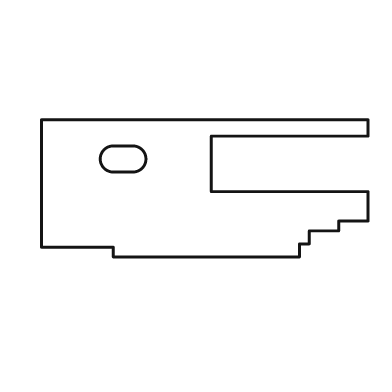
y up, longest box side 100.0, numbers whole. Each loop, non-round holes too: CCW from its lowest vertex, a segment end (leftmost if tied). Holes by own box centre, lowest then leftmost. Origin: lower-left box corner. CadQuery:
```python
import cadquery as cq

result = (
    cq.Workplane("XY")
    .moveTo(22.0, 0.0)
    .lineTo(79.0, 0.0)
    .lineTo(79.0, 4.0)
    .lineTo(82.0, 4.0)
    .lineTo(82.0, 8.0)
    .lineTo(91.0, 8.0)
    .lineTo(91.0, 11.0)
    .lineTo(100.0, 11.0)
    .lineTo(100.0, 20.0)
    .lineTo(52.0, 20.0)
    .lineTo(52.0, 37.0)
    .lineTo(100.0, 37.0)
    .lineTo(100.0, 42.0)
    .lineTo(0.0, 42.0)
    .lineTo(0.0, 3.0)
    .lineTo(22.0, 3.0)
    .close()
    .moveTo(22.0, 26.0)
    .lineTo(28.0, 26.0)
    .threePointArc((32.0, 30.0), (28.0, 34.0))
    .lineTo(22.0, 34.0)
    .threePointArc((18.0, 30.0), (22.0, 26.0))
    .close()
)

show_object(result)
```